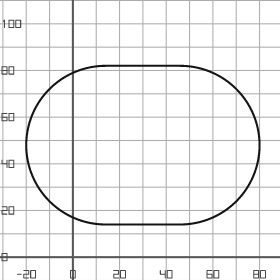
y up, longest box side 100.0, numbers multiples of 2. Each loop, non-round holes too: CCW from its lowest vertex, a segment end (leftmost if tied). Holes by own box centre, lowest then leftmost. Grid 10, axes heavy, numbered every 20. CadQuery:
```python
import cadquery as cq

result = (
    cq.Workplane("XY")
    .moveTo(14.0, 14.0)
    .lineTo(46.0, 14.0)
    .threePointArc((80.0, 48.0), (46.0, 82.0))
    .lineTo(14.0, 82.0)
    .threePointArc((-20.0, 48.0), (14.0, 14.0))
    .close()
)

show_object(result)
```